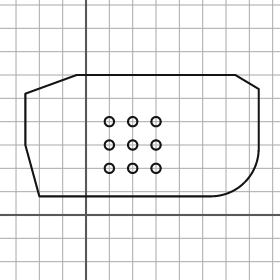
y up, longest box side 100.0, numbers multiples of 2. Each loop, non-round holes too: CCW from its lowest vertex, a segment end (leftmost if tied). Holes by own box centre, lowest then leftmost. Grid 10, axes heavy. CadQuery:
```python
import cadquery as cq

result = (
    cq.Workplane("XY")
    .moveTo(-20.0, 8.0)
    .lineTo(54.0, 8.0)
    .threePointArc((68.0, 14.0), (74.0, 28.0))
    .lineTo(74.0, 54.0)
    .lineTo(64.0, 60.0)
    .lineTo(-4.0, 60.0)
    .lineTo(-26.0, 52.0)
    .lineTo(-26.0, 30.0)
    .close()
    .moveTo(10.0, 20.0)
    .circle(2.0)
    .moveTo(20.0, 20.0)
    .circle(2.0)
    .moveTo(30.0, 20.0)
    .circle(2.0)
    .moveTo(10.0, 30.0)
    .circle(2.0)
    .moveTo(20.0, 30.0)
    .circle(2.0)
    .moveTo(30.0, 30.0)
    .circle(2.0)
    .moveTo(10.0, 40.0)
    .circle(2.0)
    .moveTo(20.0, 40.0)
    .circle(2.0)
    .moveTo(30.0, 40.0)
    .circle(2.0)
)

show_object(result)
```